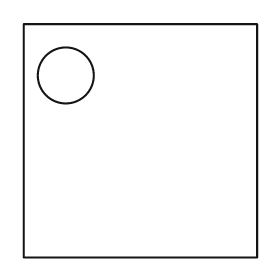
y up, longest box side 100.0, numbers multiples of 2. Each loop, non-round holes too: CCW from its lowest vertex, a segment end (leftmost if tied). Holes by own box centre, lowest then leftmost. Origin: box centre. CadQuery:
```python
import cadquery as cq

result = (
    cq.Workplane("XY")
    .moveTo(-50.0, -50.0)
    .lineTo(50.0, -50.0)
    .lineTo(50.0, 50.0)
    .lineTo(-50.0, 50.0)
    .close()
    .moveTo(-32.0, 28.0)
    .circle(12.0)
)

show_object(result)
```